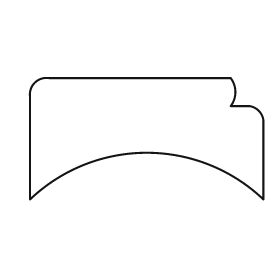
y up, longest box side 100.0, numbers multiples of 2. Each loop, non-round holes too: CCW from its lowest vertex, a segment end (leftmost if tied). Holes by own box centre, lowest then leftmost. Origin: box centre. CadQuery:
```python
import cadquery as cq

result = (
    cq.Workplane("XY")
    .moveTo(-50.0, -26.0)
    .threePointArc((0.0, -6.0), (50.0, -26.0))
    .lineTo(50.0, 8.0)
    .threePointArc((48.0, 12.0), (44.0, 14.0))
    .lineTo(36.0, 14.0)
    .threePointArc((38.0, 20.0), (36.0, 26.0))
    .lineTo(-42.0, 26.0)
    .threePointArc((-48.0, 24.0), (-50.0, 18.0))
    .close()
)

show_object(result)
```